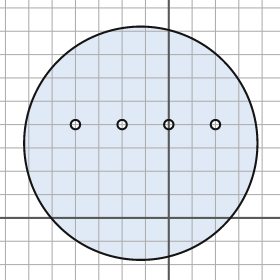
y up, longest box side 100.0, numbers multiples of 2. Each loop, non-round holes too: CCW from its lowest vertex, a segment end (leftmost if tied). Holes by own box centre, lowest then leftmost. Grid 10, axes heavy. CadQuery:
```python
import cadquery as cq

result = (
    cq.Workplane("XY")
    .moveTo(-12.0, 32.0)
    .circle(50.0)
    .moveTo(-40.0, 40.0)
    .circle(2.0)
    .moveTo(-20.0, 40.0)
    .circle(2.0)
    .moveTo(0.0, 40.0)
    .circle(2.0)
    .moveTo(20.0, 40.0)
    .circle(2.0)
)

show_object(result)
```